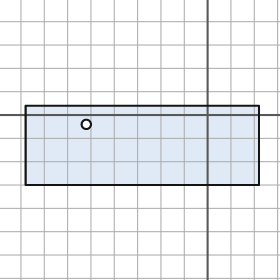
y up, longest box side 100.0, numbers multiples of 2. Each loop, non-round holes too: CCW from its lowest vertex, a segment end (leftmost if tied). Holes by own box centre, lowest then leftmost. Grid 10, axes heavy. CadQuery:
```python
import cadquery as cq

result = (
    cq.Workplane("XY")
    .moveTo(-78.0, -30.0)
    .lineTo(22.0, -30.0)
    .lineTo(22.0, 4.0)
    .lineTo(-78.0, 4.0)
    .close()
    .moveTo(-52.0, -4.0)
    .circle(2.0)
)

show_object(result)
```